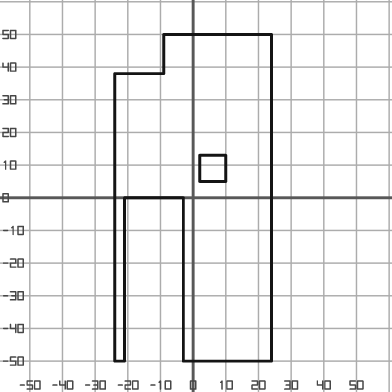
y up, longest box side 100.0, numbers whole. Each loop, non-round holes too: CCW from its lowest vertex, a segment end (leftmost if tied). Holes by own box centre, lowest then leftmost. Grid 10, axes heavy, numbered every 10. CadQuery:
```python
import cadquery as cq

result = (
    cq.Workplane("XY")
    .moveTo(-24.0, -50.0)
    .lineTo(-21.0, -50.0)
    .lineTo(-21.0, 0.0)
    .lineTo(-3.0, 0.0)
    .lineTo(-3.0, -50.0)
    .lineTo(24.0, -50.0)
    .lineTo(24.0, 50.0)
    .lineTo(-9.0, 50.0)
    .lineTo(-9.0, 38.0)
    .lineTo(-24.0, 38.0)
    .close()
    .moveTo(2.0, 5.0)
    .lineTo(10.0, 5.0)
    .lineTo(10.0, 13.0)
    .lineTo(2.0, 13.0)
    .close()
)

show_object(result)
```